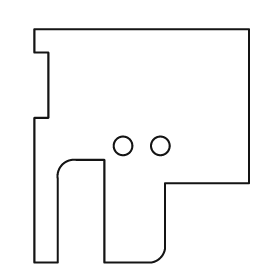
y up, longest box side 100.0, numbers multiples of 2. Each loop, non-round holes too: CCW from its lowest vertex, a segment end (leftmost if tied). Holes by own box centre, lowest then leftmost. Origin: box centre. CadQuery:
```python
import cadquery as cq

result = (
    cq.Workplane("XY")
    .moveTo(-46.0, -50.0)
    .lineTo(-36.0, -50.0)
    .lineTo(-36.0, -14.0)
    .threePointArc((-34.0, -8.0), (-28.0, -6.0))
    .lineTo(-16.0, -6.0)
    .lineTo(-16.0, -50.0)
    .lineTo(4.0, -50.0)
    .threePointArc((8.0, -48.0), (10.0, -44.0))
    .lineTo(10.0, -16.0)
    .lineTo(46.0, -16.0)
    .lineTo(46.0, 50.0)
    .lineTo(-46.0, 50.0)
    .lineTo(-46.0, 40.0)
    .lineTo(-40.0, 40.0)
    .lineTo(-40.0, 12.0)
    .lineTo(-46.0, 12.0)
    .close()
    .moveTo(-8.0, 0.0)
    .circle(4.0)
    .moveTo(8.0, 0.0)
    .circle(4.0)
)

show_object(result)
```